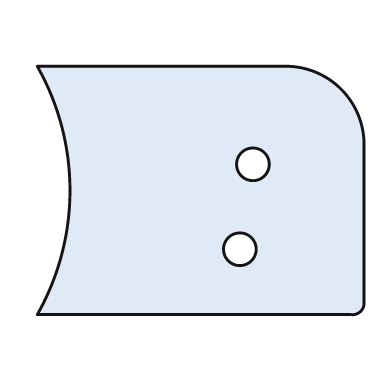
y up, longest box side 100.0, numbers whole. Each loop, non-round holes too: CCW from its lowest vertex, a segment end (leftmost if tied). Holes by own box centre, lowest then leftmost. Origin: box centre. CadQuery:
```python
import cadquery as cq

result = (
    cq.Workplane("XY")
    .moveTo(-50.0, -38.0)
    .lineTo(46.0, -38.0)
    .threePointArc((49.0, -37.0), (50.0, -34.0))
    .lineTo(50.0, 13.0)
    .threePointArc((43.0, 31.0), (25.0, 38.0))
    .lineTo(-50.0, 38.0)
    .threePointArc((-40.0, 0.0), (-50.0, -38.0))
    .close()
    .moveTo(12.0, -18.0)
    .circle(5.0)
    .moveTo(16.0, 8.0)
    .circle(5.0)
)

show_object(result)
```